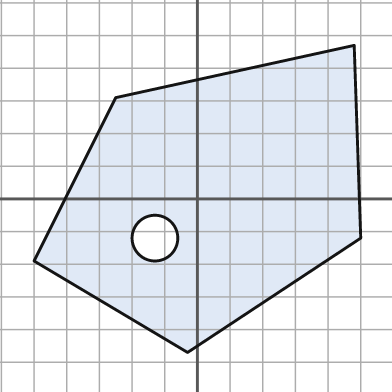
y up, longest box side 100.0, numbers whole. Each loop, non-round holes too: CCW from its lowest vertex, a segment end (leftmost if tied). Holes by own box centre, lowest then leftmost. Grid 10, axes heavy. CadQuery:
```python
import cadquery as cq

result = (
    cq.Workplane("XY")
    .moveTo(-3.0, -47.0)
    .lineTo(50.0, -12.0)
    .lineTo(48.0, 47.0)
    .lineTo(-25.0, 31.0)
    .lineTo(-50.0, -19.0)
    .close()
    .moveTo(-13.0, -12.0)
    .circle(7.0)
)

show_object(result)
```